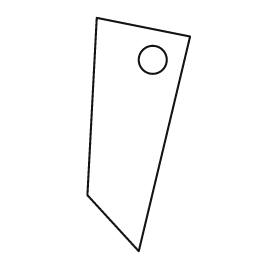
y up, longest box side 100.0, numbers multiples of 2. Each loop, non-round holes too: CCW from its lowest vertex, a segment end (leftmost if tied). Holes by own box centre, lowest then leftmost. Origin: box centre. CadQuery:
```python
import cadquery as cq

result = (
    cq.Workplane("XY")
    .moveTo(0.0, -50.0)
    .lineTo(22.0, 42.0)
    .lineTo(-18.0, 50.0)
    .lineTo(-22.0, -26.0)
    .close()
    .moveTo(6.0, 32.0)
    .circle(6.0)
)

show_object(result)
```